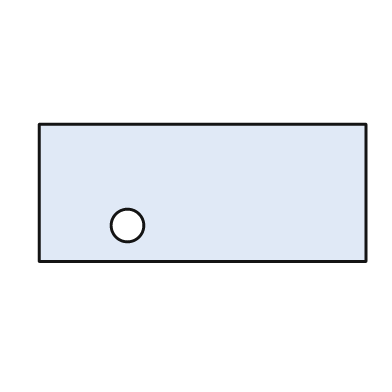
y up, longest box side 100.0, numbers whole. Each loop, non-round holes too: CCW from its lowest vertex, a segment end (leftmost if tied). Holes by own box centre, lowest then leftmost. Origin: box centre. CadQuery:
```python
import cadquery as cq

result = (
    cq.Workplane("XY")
    .moveTo(-50.0, -21.0)
    .lineTo(50.0, -21.0)
    .lineTo(50.0, 21.0)
    .lineTo(-50.0, 21.0)
    .close()
    .moveTo(-23.0, -10.0)
    .circle(5.0)
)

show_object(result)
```